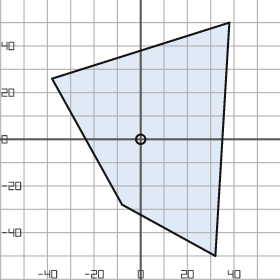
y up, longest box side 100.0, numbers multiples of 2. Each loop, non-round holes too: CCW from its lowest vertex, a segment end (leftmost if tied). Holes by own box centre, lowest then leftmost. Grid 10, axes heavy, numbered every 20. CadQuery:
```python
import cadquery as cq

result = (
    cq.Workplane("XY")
    .moveTo(32.0, -50.0)
    .lineTo(38.0, 50.0)
    .lineTo(-38.0, 26.0)
    .lineTo(-8.0, -28.0)
    .close()
    .moveTo(0.0, 0.0)
    .circle(2.0)
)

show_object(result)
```